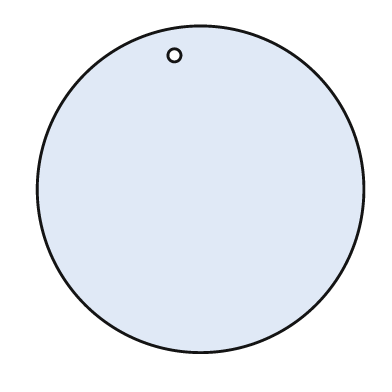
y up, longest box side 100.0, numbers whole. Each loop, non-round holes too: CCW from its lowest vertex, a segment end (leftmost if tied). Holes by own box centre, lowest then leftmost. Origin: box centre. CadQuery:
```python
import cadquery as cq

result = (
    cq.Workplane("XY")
    .moveTo(0.0, 0.0)
    .circle(50.0)
    .moveTo(-8.0, 41.0)
    .circle(2.0)
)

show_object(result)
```